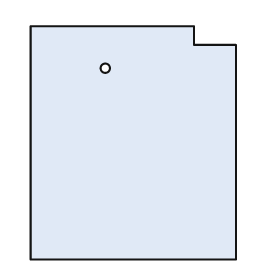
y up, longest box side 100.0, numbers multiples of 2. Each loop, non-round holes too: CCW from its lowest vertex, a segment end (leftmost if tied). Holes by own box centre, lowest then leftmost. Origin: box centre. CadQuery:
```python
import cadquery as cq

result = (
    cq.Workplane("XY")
    .moveTo(-44.0, -50.0)
    .lineTo(44.0, -50.0)
    .lineTo(44.0, 42.0)
    .lineTo(26.0, 42.0)
    .lineTo(26.0, 50.0)
    .lineTo(-44.0, 50.0)
    .close()
    .moveTo(-12.0, 32.0)
    .circle(2.0)
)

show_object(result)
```